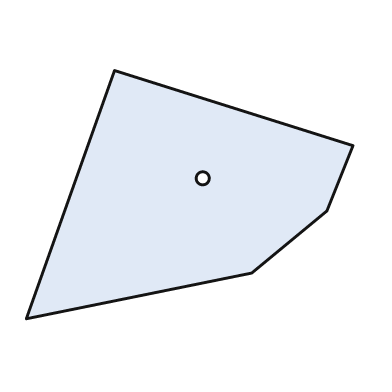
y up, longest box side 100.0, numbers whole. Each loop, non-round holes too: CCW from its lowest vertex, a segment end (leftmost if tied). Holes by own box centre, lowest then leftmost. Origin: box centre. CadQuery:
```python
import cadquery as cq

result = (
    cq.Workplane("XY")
    .moveTo(-50.0, -38.0)
    .lineTo(19.0, -24.0)
    .lineTo(42.0, -5.0)
    .lineTo(50.0, 15.0)
    .lineTo(-23.0, 38.0)
    .close()
    .moveTo(4.0, 5.0)
    .circle(2.0)
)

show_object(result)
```